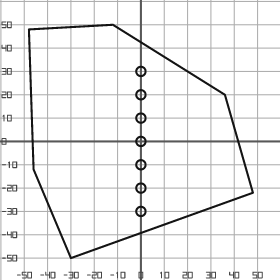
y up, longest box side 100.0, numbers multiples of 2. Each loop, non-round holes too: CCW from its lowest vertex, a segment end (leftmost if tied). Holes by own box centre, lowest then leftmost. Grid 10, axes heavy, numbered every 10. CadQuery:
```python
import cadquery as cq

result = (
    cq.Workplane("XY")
    .moveTo(-30.0, -50.0)
    .lineTo(48.0, -22.0)
    .lineTo(36.0, 20.0)
    .lineTo(-12.0, 50.0)
    .lineTo(-48.0, 48.0)
    .lineTo(-46.0, -12.0)
    .close()
    .moveTo(0.0, -30.0)
    .circle(2.0)
    .moveTo(0.0, -20.0)
    .circle(2.0)
    .moveTo(0.0, -10.0)
    .circle(2.0)
    .moveTo(0.0, 0.0)
    .circle(2.0)
    .moveTo(0.0, 10.0)
    .circle(2.0)
    .moveTo(0.0, 20.0)
    .circle(2.0)
    .moveTo(0.0, 30.0)
    .circle(2.0)
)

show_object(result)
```